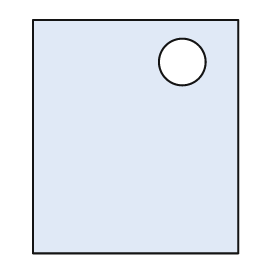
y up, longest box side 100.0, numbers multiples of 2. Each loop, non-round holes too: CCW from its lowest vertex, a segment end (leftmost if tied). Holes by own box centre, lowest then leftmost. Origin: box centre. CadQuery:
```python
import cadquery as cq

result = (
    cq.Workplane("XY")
    .moveTo(-44.0, -50.0)
    .lineTo(44.0, -50.0)
    .lineTo(44.0, 50.0)
    .lineTo(-44.0, 50.0)
    .close()
    .moveTo(20.0, 32.0)
    .circle(10.0)
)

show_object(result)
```